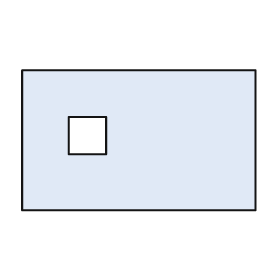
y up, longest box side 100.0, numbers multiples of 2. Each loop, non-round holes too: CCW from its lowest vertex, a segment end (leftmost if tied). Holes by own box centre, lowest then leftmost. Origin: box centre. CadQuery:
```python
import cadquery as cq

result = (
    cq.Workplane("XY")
    .moveTo(-50.0, -30.0)
    .lineTo(50.0, -30.0)
    .lineTo(50.0, 30.0)
    .lineTo(-50.0, 30.0)
    .close()
    .moveTo(-30.0, -6.0)
    .lineTo(-14.0, -6.0)
    .lineTo(-14.0, 10.0)
    .lineTo(-30.0, 10.0)
    .close()
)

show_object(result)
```